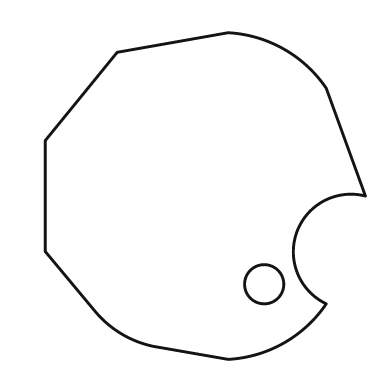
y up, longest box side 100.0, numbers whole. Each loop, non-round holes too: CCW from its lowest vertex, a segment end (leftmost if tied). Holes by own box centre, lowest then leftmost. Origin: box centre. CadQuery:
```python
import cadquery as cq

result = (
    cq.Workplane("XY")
    .moveTo(7.0, -50.0)
    .threePointArc((24.0, -45.0), (37.0, -33.0))
    .threePointArc((28.0, -11.0), (49.0, 0.0))
    .lineTo(37.0, 33.0)
    .threePointArc((24.0, 45.0), (7.0, 50.0))
    .lineTo(-27.0, 44.0)
    .lineTo(-49.0, 17.0)
    .lineTo(-49.0, -17.0)
    .lineTo(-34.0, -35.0)
    .threePointArc((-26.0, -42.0), (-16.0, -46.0))
    .close()
    .moveTo(18.0, -27.0)
    .circle(6.0)
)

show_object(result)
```